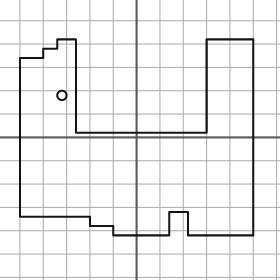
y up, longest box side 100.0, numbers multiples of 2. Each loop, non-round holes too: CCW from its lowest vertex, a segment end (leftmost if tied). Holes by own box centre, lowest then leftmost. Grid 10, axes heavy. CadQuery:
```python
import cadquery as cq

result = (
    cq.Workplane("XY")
    .moveTo(-10.0, -42.0)
    .lineTo(14.0, -42.0)
    .lineTo(14.0, -32.0)
    .lineTo(22.0, -32.0)
    .lineTo(22.0, -42.0)
    .lineTo(50.0, -42.0)
    .lineTo(50.0, 42.0)
    .lineTo(30.0, 42.0)
    .lineTo(30.0, 2.0)
    .lineTo(-26.0, 2.0)
    .lineTo(-26.0, 42.0)
    .lineTo(-34.0, 42.0)
    .lineTo(-34.0, 38.0)
    .lineTo(-40.0, 38.0)
    .lineTo(-40.0, 34.0)
    .lineTo(-50.0, 34.0)
    .lineTo(-50.0, -34.0)
    .lineTo(-20.0, -34.0)
    .lineTo(-20.0, -38.0)
    .lineTo(-10.0, -38.0)
    .close()
    .moveTo(-32.0, 18.0)
    .circle(2.0)
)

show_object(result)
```